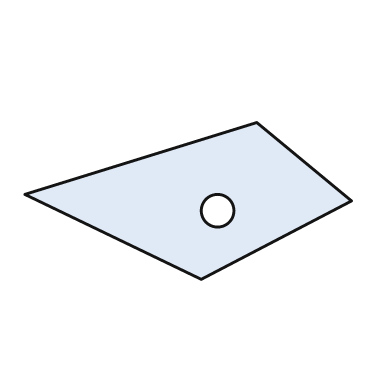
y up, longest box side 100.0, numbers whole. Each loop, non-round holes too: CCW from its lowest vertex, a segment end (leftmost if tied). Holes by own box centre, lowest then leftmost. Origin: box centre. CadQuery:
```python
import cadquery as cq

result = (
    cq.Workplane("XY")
    .moveTo(4.0, -24.0)
    .lineTo(50.0, 0.0)
    .lineTo(21.0, 24.0)
    .lineTo(-50.0, 2.0)
    .close()
    .moveTo(9.0, -3.0)
    .circle(5.0)
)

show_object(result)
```